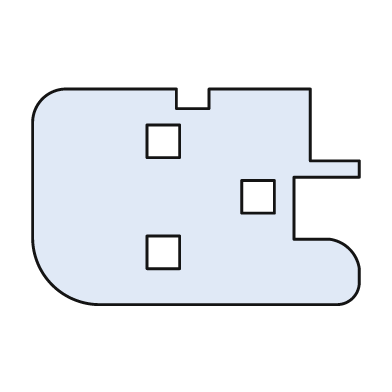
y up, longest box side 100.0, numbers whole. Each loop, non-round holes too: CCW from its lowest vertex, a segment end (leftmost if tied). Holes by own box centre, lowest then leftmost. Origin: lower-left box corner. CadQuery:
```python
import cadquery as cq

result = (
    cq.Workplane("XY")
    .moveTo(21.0, 0.0)
    .lineTo(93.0, 0.0)
    .threePointArc((98.0, 2.0), (100.0, 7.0))
    .lineTo(100.0, 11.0)
    .threePointArc((97.0, 17.0), (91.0, 20.0))
    .lineTo(80.0, 20.0)
    .lineTo(80.0, 39.0)
    .lineTo(100.0, 39.0)
    .lineTo(100.0, 44.0)
    .lineTo(85.0, 44.0)
    .lineTo(85.0, 66.0)
    .lineTo(54.0, 66.0)
    .lineTo(54.0, 60.0)
    .lineTo(44.0, 60.0)
    .lineTo(44.0, 66.0)
    .lineTo(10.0, 66.0)
    .threePointArc((3.0, 63.0), (0.0, 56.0))
    .lineTo(0.0, 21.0)
    .threePointArc((6.0, 6.0), (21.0, 0.0))
    .close()
    .moveTo(35.0, 11.0)
    .lineTo(45.0, 11.0)
    .lineTo(45.0, 21.0)
    .lineTo(35.0, 21.0)
    .close()
    .moveTo(64.0, 28.0)
    .lineTo(74.0, 28.0)
    .lineTo(74.0, 38.0)
    .lineTo(64.0, 38.0)
    .close()
    .moveTo(35.0, 45.0)
    .lineTo(45.0, 45.0)
    .lineTo(45.0, 55.0)
    .lineTo(35.0, 55.0)
    .close()
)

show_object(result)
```